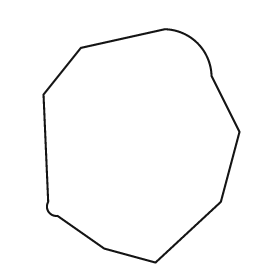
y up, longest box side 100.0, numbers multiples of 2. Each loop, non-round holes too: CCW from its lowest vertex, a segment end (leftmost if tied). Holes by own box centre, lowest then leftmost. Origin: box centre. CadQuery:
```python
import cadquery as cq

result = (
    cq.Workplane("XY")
    .moveTo(6.0, -50.0)
    .lineTo(34.0, -24.0)
    .lineTo(42.0, 6.0)
    .lineTo(30.0, 30.0)
    .threePointArc((24.0, 44.0), (10.0, 50.0))
    .lineTo(-26.0, 42.0)
    .lineTo(-42.0, 22.0)
    .lineTo(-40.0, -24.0)
    .threePointArc((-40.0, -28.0), (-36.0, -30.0))
    .lineTo(-16.0, -44.0)
    .close()
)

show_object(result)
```